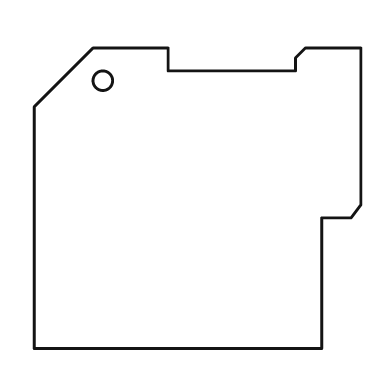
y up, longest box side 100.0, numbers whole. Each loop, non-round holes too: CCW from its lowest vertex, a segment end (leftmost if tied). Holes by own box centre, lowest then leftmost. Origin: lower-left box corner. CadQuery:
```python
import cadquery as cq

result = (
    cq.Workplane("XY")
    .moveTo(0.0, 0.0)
    .lineTo(88.0, 0.0)
    .lineTo(88.0, 40.0)
    .lineTo(97.0, 40.0)
    .lineTo(100.0, 44.0)
    .lineTo(100.0, 92.0)
    .lineTo(83.0, 92.0)
    .lineTo(80.0, 89.0)
    .lineTo(80.0, 85.0)
    .lineTo(41.0, 85.0)
    .lineTo(41.0, 92.0)
    .lineTo(18.0, 92.0)
    .lineTo(0.0, 74.0)
    .close()
    .moveTo(21.0, 82.0)
    .circle(3.0)
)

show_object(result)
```